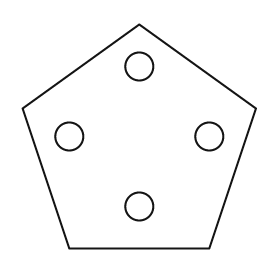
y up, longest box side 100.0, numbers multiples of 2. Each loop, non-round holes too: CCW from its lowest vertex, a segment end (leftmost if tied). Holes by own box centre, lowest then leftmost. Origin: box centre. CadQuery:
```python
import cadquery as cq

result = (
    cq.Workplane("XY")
    .moveTo(-30.0, -48.0)
    .lineTo(30.0, -48.0)
    .lineTo(50.0, 12.0)
    .lineTo(0.0, 48.0)
    .lineTo(-50.0, 12.0)
    .close()
    .moveTo(0.0, -30.0)
    .circle(6.0)
    .moveTo(-30.0, 0.0)
    .circle(6.0)
    .moveTo(30.0, 0.0)
    .circle(6.0)
    .moveTo(0.0, 30.0)
    .circle(6.0)
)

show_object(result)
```